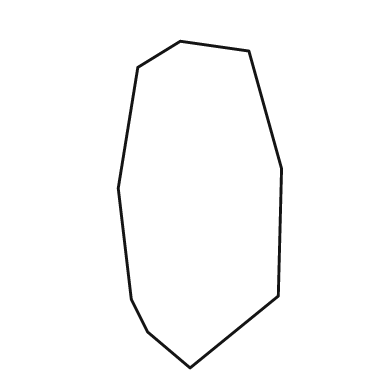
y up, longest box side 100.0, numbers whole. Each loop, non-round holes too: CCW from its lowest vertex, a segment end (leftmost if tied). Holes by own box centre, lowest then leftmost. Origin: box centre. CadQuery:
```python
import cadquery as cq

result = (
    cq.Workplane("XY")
    .moveTo(-3.0, -50.0)
    .lineTo(24.0, -28.0)
    .lineTo(25.0, 11.0)
    .lineTo(15.0, 47.0)
    .lineTo(-6.0, 50.0)
    .lineTo(-19.0, 42.0)
    .lineTo(-25.0, 5.0)
    .lineTo(-21.0, -29.0)
    .lineTo(-16.0, -39.0)
    .close()
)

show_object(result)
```